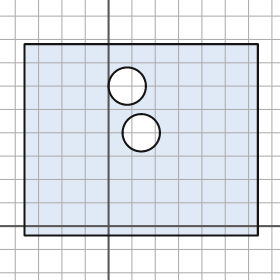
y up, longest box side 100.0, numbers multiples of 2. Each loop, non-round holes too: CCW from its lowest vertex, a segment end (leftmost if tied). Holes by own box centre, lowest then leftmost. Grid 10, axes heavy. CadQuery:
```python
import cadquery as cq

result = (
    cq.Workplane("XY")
    .moveTo(-36.0, -4.0)
    .lineTo(64.0, -4.0)
    .lineTo(64.0, 78.0)
    .lineTo(-36.0, 78.0)
    .close()
    .moveTo(14.0, 40.0)
    .circle(8.0)
    .moveTo(8.0, 60.0)
    .circle(8.0)
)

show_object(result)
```